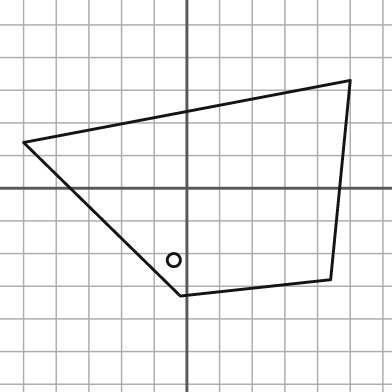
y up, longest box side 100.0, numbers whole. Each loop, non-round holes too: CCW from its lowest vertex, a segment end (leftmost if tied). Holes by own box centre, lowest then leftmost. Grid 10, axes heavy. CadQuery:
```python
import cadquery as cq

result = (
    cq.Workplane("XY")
    .moveTo(-2.0, -33.0)
    .lineTo(44.0, -28.0)
    .lineTo(50.0, 33.0)
    .lineTo(-50.0, 14.0)
    .close()
    .moveTo(-4.0, -22.0)
    .circle(2.0)
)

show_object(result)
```